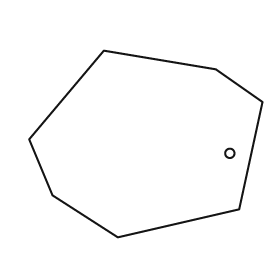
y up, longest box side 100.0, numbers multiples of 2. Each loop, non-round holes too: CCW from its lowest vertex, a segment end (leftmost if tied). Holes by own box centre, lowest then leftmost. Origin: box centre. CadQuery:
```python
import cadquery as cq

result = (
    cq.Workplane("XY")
    .moveTo(-12.0, -40.0)
    .lineTo(40.0, -28.0)
    .lineTo(50.0, 18.0)
    .lineTo(30.0, 32.0)
    .lineTo(-18.0, 40.0)
    .lineTo(-50.0, 2.0)
    .lineTo(-40.0, -22.0)
    .close()
    .moveTo(36.0, -4.0)
    .circle(2.0)
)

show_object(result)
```